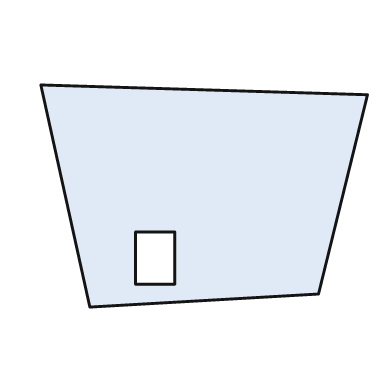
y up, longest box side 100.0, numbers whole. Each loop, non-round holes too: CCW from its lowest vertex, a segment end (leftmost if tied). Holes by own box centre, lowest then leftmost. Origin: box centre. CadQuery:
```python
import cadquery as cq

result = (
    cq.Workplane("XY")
    .moveTo(-35.0, -34.0)
    .lineTo(35.0, -30.0)
    .lineTo(50.0, 31.0)
    .lineTo(-50.0, 34.0)
    .close()
    .moveTo(-21.0, -27.0)
    .lineTo(-9.0, -27.0)
    .lineTo(-9.0, -11.0)
    .lineTo(-21.0, -11.0)
    .close()
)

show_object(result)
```